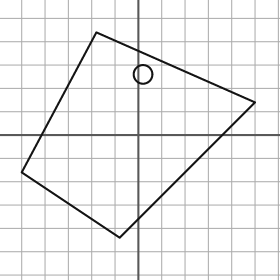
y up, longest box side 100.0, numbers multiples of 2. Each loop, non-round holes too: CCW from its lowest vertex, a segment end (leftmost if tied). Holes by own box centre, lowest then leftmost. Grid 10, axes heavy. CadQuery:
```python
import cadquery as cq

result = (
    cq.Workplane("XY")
    .moveTo(-8.0, -44.0)
    .lineTo(50.0, 14.0)
    .lineTo(-18.0, 44.0)
    .lineTo(-50.0, -16.0)
    .close()
    .moveTo(2.0, 26.0)
    .circle(4.0)
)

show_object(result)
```